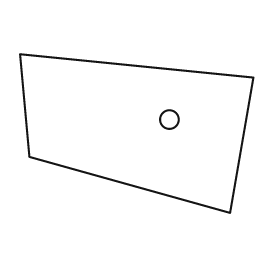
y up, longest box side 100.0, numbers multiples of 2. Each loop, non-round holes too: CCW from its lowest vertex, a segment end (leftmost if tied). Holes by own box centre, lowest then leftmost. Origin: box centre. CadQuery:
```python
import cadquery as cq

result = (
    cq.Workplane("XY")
    .moveTo(40.0, -34.0)
    .lineTo(50.0, 24.0)
    .lineTo(-50.0, 34.0)
    .lineTo(-46.0, -10.0)
    .close()
    .moveTo(14.0, 6.0)
    .circle(4.0)
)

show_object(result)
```